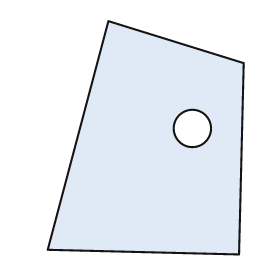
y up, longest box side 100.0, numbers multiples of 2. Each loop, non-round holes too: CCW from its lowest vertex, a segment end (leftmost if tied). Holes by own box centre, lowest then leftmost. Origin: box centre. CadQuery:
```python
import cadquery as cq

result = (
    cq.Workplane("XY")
    .moveTo(40.0, -50.0)
    .lineTo(42.0, 32.0)
    .lineTo(-16.0, 50.0)
    .lineTo(-42.0, -48.0)
    .close()
    .moveTo(20.0, 4.0)
    .circle(8.0)
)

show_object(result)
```